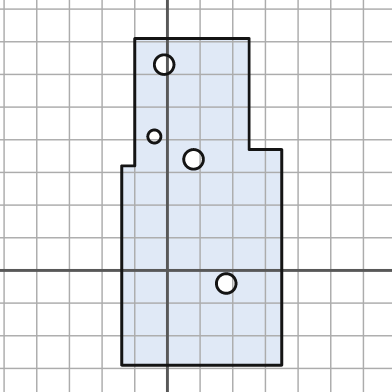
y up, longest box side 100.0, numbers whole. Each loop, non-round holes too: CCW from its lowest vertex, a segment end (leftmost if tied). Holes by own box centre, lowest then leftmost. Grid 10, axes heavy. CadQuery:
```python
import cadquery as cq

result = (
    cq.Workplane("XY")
    .moveTo(-14.0, -29.0)
    .lineTo(35.0, -29.0)
    .lineTo(35.0, 37.0)
    .lineTo(25.0, 37.0)
    .lineTo(25.0, 71.0)
    .lineTo(-10.0, 71.0)
    .lineTo(-10.0, 32.0)
    .lineTo(-14.0, 32.0)
    .close()
    .moveTo(18.0, -4.0)
    .circle(3.0)
    .moveTo(8.0, 34.0)
    .circle(3.0)
    .moveTo(-4.0, 41.0)
    .circle(2.0)
    .moveTo(-1.0, 63.0)
    .circle(3.0)
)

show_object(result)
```